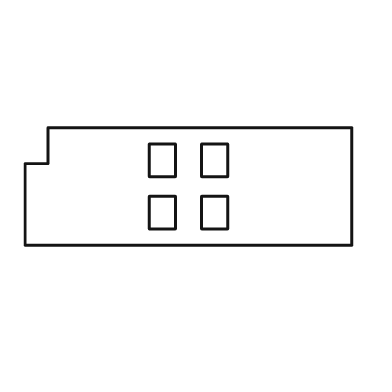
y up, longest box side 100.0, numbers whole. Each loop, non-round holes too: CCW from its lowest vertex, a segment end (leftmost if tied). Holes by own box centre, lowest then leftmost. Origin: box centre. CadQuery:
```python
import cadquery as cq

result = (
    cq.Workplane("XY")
    .moveTo(-50.0, -18.0)
    .lineTo(50.0, -18.0)
    .lineTo(50.0, 18.0)
    .lineTo(-43.0, 18.0)
    .lineTo(-43.0, 7.0)
    .lineTo(-50.0, 7.0)
    .close()
    .moveTo(-12.0, -13.0)
    .lineTo(-4.0, -13.0)
    .lineTo(-4.0, -3.0)
    .lineTo(-12.0, -3.0)
    .close()
    .moveTo(4.0, -13.0)
    .lineTo(12.0, -13.0)
    .lineTo(12.0, -3.0)
    .lineTo(4.0, -3.0)
    .close()
    .moveTo(-12.0, 3.0)
    .lineTo(-4.0, 3.0)
    .lineTo(-4.0, 13.0)
    .lineTo(-12.0, 13.0)
    .close()
    .moveTo(4.0, 3.0)
    .lineTo(12.0, 3.0)
    .lineTo(12.0, 13.0)
    .lineTo(4.0, 13.0)
    .close()
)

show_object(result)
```